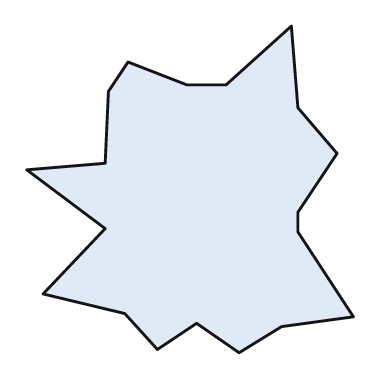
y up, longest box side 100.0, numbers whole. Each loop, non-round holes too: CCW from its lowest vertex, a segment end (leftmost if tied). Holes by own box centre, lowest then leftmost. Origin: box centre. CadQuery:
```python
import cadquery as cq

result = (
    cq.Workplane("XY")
    .moveTo(15.0, -50.0)
    .lineTo(28.0, -42.0)
    .lineTo(50.0, -39.0)
    .lineTo(33.0, -13.0)
    .lineTo(33.0, -7.0)
    .lineTo(45.0, 11.0)
    .lineTo(33.0, 25.0)
    .lineTo(31.0, 50.0)
    .lineTo(11.0, 32.0)
    .lineTo(-1.0, 32.0)
    .lineTo(-19.0, 39.0)
    .lineTo(-25.0, 30.0)
    .lineTo(-26.0, 8.0)
    .lineTo(-50.0, 6.0)
    .lineTo(-26.0, -12.0)
    .lineTo(-45.0, -32.0)
    .lineTo(-20.0, -38.0)
    .lineTo(-10.0, -49.0)
    .lineTo(2.0, -41.0)
    .close()
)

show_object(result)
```